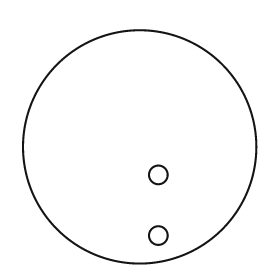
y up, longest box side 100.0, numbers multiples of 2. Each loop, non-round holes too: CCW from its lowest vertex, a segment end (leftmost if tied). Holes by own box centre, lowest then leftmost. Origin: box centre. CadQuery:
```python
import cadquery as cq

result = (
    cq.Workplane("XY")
    .moveTo(0.0, 0.0)
    .circle(50.0)
    .moveTo(8.0, -38.0)
    .circle(4.0)
    .moveTo(8.0, -12.0)
    .circle(4.0)
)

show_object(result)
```